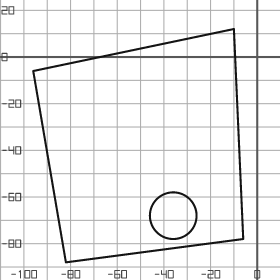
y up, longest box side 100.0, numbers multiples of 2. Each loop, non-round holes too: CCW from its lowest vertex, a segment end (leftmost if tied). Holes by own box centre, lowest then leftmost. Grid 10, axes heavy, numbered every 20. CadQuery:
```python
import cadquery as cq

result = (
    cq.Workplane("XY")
    .moveTo(-82.0, -88.0)
    .lineTo(-6.0, -78.0)
    .lineTo(-10.0, 12.0)
    .lineTo(-96.0, -6.0)
    .close()
    .moveTo(-36.0, -68.0)
    .circle(10.0)
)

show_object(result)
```